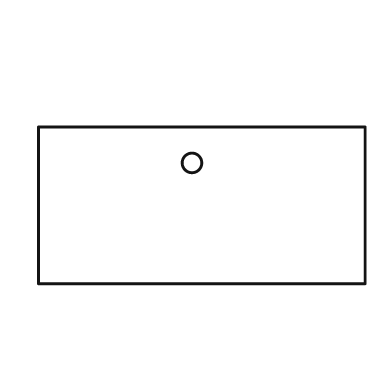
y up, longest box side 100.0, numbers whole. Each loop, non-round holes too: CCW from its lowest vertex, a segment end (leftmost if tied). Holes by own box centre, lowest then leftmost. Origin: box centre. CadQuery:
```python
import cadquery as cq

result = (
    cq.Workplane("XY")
    .moveTo(-50.0, -24.0)
    .lineTo(50.0, -24.0)
    .lineTo(50.0, 24.0)
    .lineTo(-50.0, 24.0)
    .close()
    .moveTo(-3.0, 13.0)
    .circle(3.0)
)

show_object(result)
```